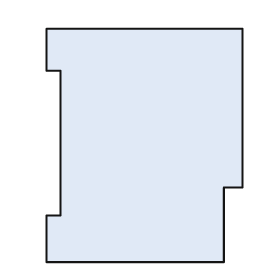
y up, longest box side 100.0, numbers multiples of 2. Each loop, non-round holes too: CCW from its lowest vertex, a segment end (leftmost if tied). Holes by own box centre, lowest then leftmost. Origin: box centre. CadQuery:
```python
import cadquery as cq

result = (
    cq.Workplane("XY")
    .moveTo(-42.0, -50.0)
    .lineTo(34.0, -50.0)
    .lineTo(34.0, -18.0)
    .lineTo(42.0, -18.0)
    .lineTo(42.0, 50.0)
    .lineTo(-42.0, 50.0)
    .lineTo(-42.0, 32.0)
    .lineTo(-36.0, 32.0)
    .lineTo(-36.0, -30.0)
    .lineTo(-42.0, -30.0)
    .close()
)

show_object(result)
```